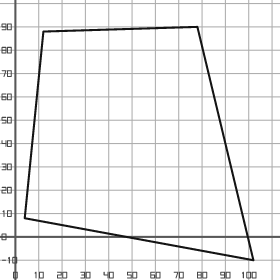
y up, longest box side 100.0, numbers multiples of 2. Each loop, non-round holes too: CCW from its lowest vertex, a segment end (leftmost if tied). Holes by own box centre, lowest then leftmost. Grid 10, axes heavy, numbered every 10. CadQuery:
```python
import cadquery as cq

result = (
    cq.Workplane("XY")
    .moveTo(102.0, -10.0)
    .lineTo(78.0, 90.0)
    .lineTo(12.0, 88.0)
    .lineTo(4.0, 8.0)
    .close()
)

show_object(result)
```